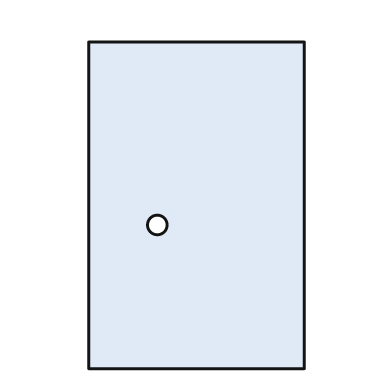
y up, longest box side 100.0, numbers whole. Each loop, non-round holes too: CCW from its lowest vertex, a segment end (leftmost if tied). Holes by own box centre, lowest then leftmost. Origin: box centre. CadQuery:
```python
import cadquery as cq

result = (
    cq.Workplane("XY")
    .moveTo(-33.0, -50.0)
    .lineTo(33.0, -50.0)
    .lineTo(33.0, 50.0)
    .lineTo(-33.0, 50.0)
    .close()
    .moveTo(-12.0, -6.0)
    .circle(3.0)
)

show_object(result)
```